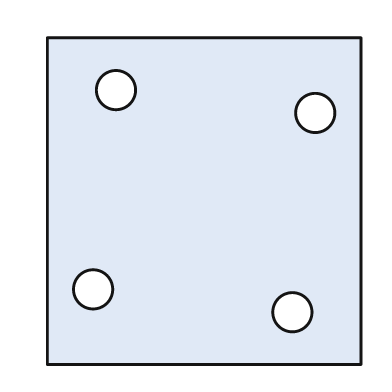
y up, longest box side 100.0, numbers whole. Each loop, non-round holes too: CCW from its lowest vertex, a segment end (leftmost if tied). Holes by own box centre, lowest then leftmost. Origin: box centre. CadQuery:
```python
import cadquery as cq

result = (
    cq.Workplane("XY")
    .moveTo(-48.0, -50.0)
    .lineTo(48.0, -50.0)
    .lineTo(48.0, 50.0)
    .lineTo(-48.0, 50.0)
    .close()
    .moveTo(27.0, -34.0)
    .circle(6.0)
    .moveTo(-34.0, -27.0)
    .circle(6.0)
    .moveTo(34.0, 27.0)
    .circle(6.0)
    .moveTo(-27.0, 34.0)
    .circle(6.0)
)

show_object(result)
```